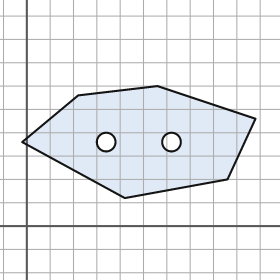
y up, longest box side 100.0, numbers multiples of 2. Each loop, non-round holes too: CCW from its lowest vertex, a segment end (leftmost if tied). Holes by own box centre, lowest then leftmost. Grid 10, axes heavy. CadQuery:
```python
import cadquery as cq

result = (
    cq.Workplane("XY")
    .moveTo(42.0, 12.0)
    .lineTo(86.0, 20.0)
    .lineTo(98.0, 46.0)
    .lineTo(56.0, 60.0)
    .lineTo(22.0, 56.0)
    .lineTo(-2.0, 36.0)
    .close()
    .moveTo(34.0, 36.0)
    .circle(4.0)
    .moveTo(62.0, 36.0)
    .circle(4.0)
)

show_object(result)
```